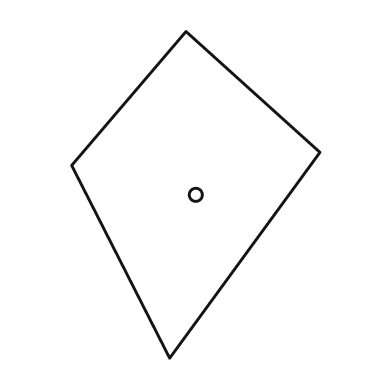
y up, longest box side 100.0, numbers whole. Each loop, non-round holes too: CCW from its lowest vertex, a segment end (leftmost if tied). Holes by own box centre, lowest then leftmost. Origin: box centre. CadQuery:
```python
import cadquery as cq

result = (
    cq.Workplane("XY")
    .moveTo(-8.0, -50.0)
    .lineTo(38.0, 13.0)
    .lineTo(-3.0, 50.0)
    .lineTo(-38.0, 9.0)
    .close()
    .moveTo(0.0, 0.0)
    .circle(2.0)
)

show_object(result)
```